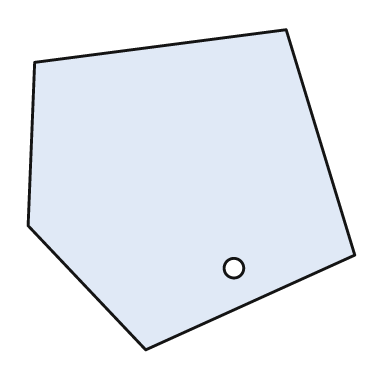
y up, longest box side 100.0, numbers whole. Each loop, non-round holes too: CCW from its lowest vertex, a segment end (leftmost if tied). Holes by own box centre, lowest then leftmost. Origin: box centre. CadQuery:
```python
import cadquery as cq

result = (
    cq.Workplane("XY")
    .moveTo(-14.0, -49.0)
    .lineTo(50.0, -20.0)
    .lineTo(29.0, 49.0)
    .lineTo(-48.0, 39.0)
    .lineTo(-50.0, -11.0)
    .close()
    .moveTo(13.0, -24.0)
    .circle(3.0)
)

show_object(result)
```